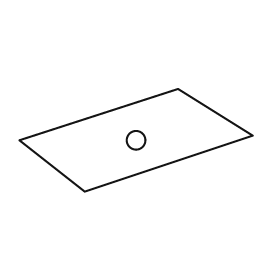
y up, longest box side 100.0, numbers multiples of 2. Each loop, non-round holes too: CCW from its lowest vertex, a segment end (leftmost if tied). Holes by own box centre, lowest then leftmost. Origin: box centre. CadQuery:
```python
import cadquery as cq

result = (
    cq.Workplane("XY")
    .moveTo(-22.0, -22.0)
    .lineTo(50.0, 2.0)
    .lineTo(18.0, 22.0)
    .lineTo(-50.0, 0.0)
    .close()
    .moveTo(0.0, 0.0)
    .circle(4.0)
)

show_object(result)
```